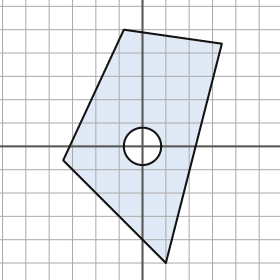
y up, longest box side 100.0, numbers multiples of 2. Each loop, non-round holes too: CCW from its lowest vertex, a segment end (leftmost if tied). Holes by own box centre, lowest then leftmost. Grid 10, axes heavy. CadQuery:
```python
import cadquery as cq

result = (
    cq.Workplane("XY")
    .moveTo(10.0, -50.0)
    .lineTo(34.0, 44.0)
    .lineTo(-8.0, 50.0)
    .lineTo(-34.0, -6.0)
    .close()
    .moveTo(0.0, 0.0)
    .circle(8.0)
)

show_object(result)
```